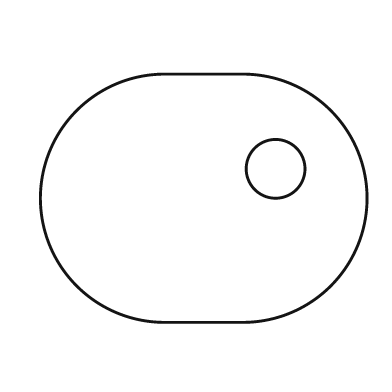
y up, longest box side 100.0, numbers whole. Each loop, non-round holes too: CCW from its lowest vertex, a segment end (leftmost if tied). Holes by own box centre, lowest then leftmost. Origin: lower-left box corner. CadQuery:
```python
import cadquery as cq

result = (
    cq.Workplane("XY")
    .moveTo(38.0, 0.0)
    .lineTo(62.0, 0.0)
    .threePointArc((100.0, 38.0), (62.0, 76.0))
    .lineTo(38.0, 76.0)
    .threePointArc((0.0, 38.0), (38.0, 0.0))
    .close()
    .moveTo(72.0, 47.0)
    .circle(9.0)
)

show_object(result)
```